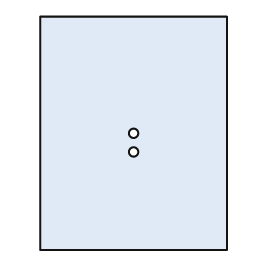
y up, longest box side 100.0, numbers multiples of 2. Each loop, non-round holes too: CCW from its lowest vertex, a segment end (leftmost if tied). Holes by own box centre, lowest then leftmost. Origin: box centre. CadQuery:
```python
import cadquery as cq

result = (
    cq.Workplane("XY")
    .moveTo(-40.0, -50.0)
    .lineTo(40.0, -50.0)
    .lineTo(40.0, 50.0)
    .lineTo(-40.0, 50.0)
    .close()
    .moveTo(0.0, -8.0)
    .circle(2.0)
    .moveTo(0.0, 0.0)
    .circle(2.0)
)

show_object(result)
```